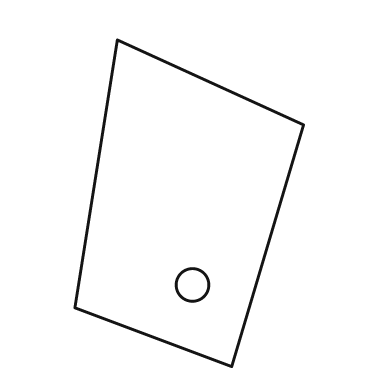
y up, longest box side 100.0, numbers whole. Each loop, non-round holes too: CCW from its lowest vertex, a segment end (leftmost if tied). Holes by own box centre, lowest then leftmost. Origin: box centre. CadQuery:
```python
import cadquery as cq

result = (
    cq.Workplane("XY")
    .moveTo(13.0, -50.0)
    .lineTo(35.0, 24.0)
    .lineTo(-22.0, 50.0)
    .lineTo(-35.0, -32.0)
    .close()
    .moveTo(1.0, -25.0)
    .circle(5.0)
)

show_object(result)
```